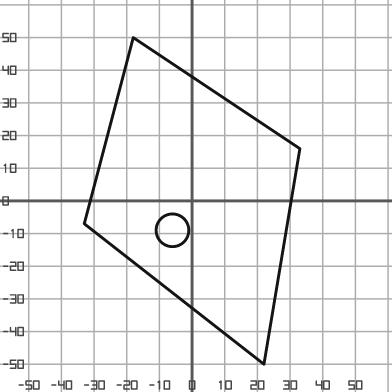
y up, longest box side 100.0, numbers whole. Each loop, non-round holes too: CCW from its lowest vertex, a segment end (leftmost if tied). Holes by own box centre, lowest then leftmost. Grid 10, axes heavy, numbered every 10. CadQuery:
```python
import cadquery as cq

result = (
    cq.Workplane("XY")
    .moveTo(22.0, -50.0)
    .lineTo(33.0, 16.0)
    .lineTo(-18.0, 50.0)
    .lineTo(-33.0, -7.0)
    .close()
    .moveTo(-6.0, -9.0)
    .circle(5.0)
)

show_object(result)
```